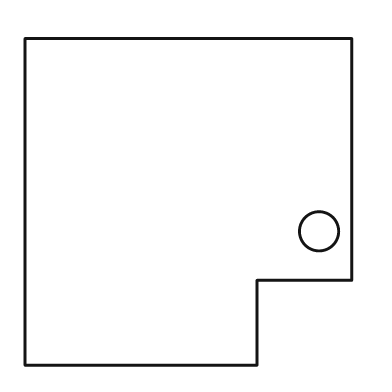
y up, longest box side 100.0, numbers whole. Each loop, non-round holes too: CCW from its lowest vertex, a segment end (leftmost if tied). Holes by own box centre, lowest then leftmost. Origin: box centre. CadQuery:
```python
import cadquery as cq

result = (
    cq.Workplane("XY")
    .moveTo(-50.0, -50.0)
    .lineTo(21.0, -50.0)
    .lineTo(21.0, -24.0)
    .lineTo(50.0, -24.0)
    .lineTo(50.0, 50.0)
    .lineTo(-50.0, 50.0)
    .close()
    .moveTo(40.0, -9.0)
    .circle(6.0)
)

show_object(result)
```